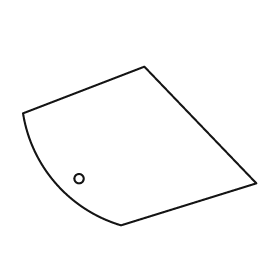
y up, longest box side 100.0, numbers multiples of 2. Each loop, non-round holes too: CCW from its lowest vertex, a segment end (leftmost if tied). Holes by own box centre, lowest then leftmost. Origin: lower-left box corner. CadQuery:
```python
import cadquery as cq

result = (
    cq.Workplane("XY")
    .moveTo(42.0, 0.0)
    .lineTo(100.0, 18.0)
    .lineTo(52.0, 68.0)
    .lineTo(0.0, 48.0)
    .threePointArc((14.0, 18.0), (42.0, 0.0))
    .close()
    .moveTo(24.0, 20.0)
    .circle(2.0)
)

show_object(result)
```